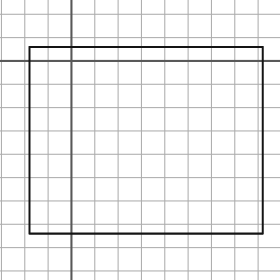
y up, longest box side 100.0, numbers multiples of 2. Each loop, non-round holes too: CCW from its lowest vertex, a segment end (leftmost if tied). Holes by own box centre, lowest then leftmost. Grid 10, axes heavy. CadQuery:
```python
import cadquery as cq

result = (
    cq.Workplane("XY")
    .moveTo(-18.0, -74.0)
    .lineTo(82.0, -74.0)
    .lineTo(82.0, 6.0)
    .lineTo(-18.0, 6.0)
    .close()
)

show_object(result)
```